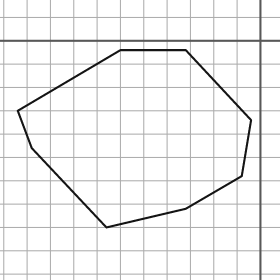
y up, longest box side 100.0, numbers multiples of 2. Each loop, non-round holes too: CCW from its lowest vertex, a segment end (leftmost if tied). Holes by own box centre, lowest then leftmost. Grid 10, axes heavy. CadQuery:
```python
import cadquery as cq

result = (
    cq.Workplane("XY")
    .moveTo(-66.0, -80.0)
    .lineTo(-32.0, -72.0)
    .lineTo(-8.0, -58.0)
    .lineTo(-4.0, -34.0)
    .lineTo(-32.0, -4.0)
    .lineTo(-60.0, -4.0)
    .lineTo(-104.0, -30.0)
    .lineTo(-98.0, -46.0)
    .close()
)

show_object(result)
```